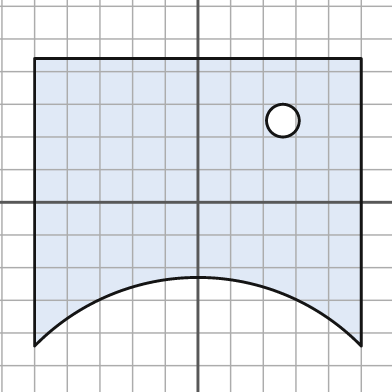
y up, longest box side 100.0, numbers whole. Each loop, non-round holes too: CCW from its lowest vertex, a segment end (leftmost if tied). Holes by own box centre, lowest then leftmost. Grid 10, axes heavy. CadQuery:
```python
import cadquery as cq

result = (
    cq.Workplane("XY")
    .moveTo(-50.0, -44.0)
    .threePointArc((0.0, -23.0), (50.0, -44.0))
    .lineTo(50.0, 44.0)
    .lineTo(-50.0, 44.0)
    .close()
    .moveTo(26.0, 25.0)
    .circle(5.0)
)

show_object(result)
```